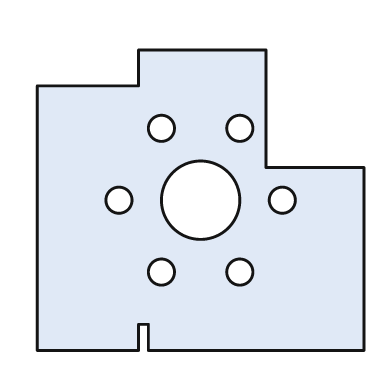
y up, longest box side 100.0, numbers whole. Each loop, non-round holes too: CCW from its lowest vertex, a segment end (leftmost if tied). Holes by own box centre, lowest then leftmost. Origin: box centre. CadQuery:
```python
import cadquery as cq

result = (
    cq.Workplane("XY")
    .moveTo(-50.0, -46.0)
    .lineTo(-19.0, -46.0)
    .lineTo(-19.0, -38.0)
    .lineTo(-16.0, -38.0)
    .lineTo(-16.0, -46.0)
    .lineTo(50.0, -46.0)
    .lineTo(50.0, 10.0)
    .lineTo(20.0, 10.0)
    .lineTo(20.0, 46.0)
    .lineTo(-19.0, 46.0)
    .lineTo(-19.0, 35.0)
    .lineTo(-50.0, 35.0)
    .close()
    .moveTo(-12.0, -22.0)
    .circle(4.0)
    .moveTo(12.0, -22.0)
    .circle(4.0)
    .moveTo(-25.0, 0.0)
    .circle(4.0)
    .moveTo(0.0, 0.0)
    .circle(12.0)
    .moveTo(25.0, 0.0)
    .circle(4.0)
    .moveTo(-12.0, 22.0)
    .circle(4.0)
    .moveTo(12.0, 22.0)
    .circle(4.0)
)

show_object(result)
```